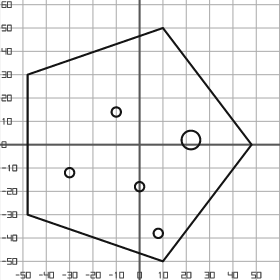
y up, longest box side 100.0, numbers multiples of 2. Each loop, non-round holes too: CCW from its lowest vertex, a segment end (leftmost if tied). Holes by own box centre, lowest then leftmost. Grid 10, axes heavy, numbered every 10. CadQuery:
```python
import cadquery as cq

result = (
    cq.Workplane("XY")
    .moveTo(10.0, -50.0)
    .lineTo(48.0, 0.0)
    .lineTo(10.0, 50.0)
    .lineTo(-48.0, 30.0)
    .lineTo(-48.0, -30.0)
    .close()
    .moveTo(8.0, -38.0)
    .circle(2.0)
    .moveTo(0.0, -18.0)
    .circle(2.0)
    .moveTo(-30.0, -12.0)
    .circle(2.0)
    .moveTo(22.0, 2.0)
    .circle(4.0)
    .moveTo(-10.0, 14.0)
    .circle(2.0)
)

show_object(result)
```